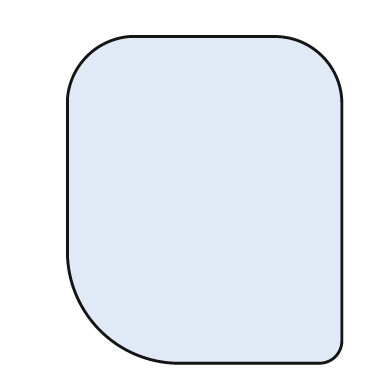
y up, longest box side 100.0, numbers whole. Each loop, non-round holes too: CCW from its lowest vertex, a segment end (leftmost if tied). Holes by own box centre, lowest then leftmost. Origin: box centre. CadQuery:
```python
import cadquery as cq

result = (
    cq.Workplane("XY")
    .moveTo(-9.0, -50.0)
    .lineTo(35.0, -50.0)
    .threePointArc((40.0, -48.0), (42.0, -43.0))
    .lineTo(42.0, 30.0)
    .threePointArc((36.0, 44.0), (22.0, 50.0))
    .lineTo(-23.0, 50.0)
    .threePointArc((-36.0, 44.0), (-42.0, 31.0))
    .lineTo(-42.0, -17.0)
    .threePointArc((-32.0, -40.0), (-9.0, -50.0))
    .close()
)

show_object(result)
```